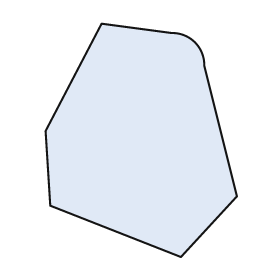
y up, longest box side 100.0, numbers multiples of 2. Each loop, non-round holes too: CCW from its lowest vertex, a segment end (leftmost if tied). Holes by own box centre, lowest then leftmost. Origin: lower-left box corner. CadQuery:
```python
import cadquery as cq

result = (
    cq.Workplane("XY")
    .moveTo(58.0, 0.0)
    .lineTo(82.0, 26.0)
    .lineTo(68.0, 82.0)
    .threePointArc((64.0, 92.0), (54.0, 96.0))
    .lineTo(24.0, 100.0)
    .lineTo(0.0, 54.0)
    .lineTo(2.0, 22.0)
    .close()
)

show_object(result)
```